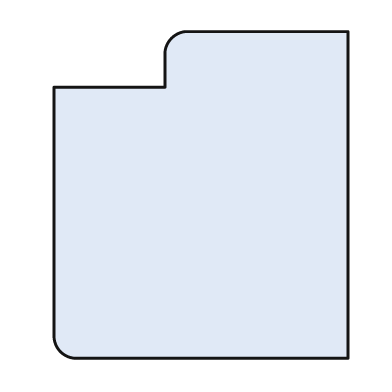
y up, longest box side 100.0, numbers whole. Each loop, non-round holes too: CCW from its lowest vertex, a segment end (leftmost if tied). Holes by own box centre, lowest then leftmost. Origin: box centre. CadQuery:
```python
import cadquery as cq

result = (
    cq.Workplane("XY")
    .moveTo(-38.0, -50.0)
    .lineTo(45.0, -50.0)
    .lineTo(45.0, 50.0)
    .lineTo(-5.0, 50.0)
    .threePointArc((-9.0, 48.0), (-11.0, 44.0))
    .lineTo(-11.0, 33.0)
    .lineTo(-45.0, 33.0)
    .lineTo(-45.0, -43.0)
    .threePointArc((-43.0, -48.0), (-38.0, -50.0))
    .close()
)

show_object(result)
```